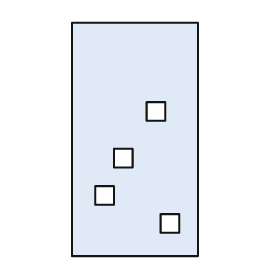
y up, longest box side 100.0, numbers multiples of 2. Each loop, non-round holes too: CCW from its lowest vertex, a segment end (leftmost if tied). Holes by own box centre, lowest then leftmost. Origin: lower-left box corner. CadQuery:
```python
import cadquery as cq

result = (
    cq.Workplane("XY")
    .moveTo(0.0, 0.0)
    .lineTo(54.0, 0.0)
    .lineTo(54.0, 100.0)
    .lineTo(0.0, 100.0)
    .close()
    .moveTo(38.0, 10.0)
    .lineTo(46.0, 10.0)
    .lineTo(46.0, 18.0)
    .lineTo(38.0, 18.0)
    .close()
    .moveTo(10.0, 22.0)
    .lineTo(18.0, 22.0)
    .lineTo(18.0, 30.0)
    .lineTo(10.0, 30.0)
    .close()
    .moveTo(18.0, 38.0)
    .lineTo(26.0, 38.0)
    .lineTo(26.0, 46.0)
    .lineTo(18.0, 46.0)
    .close()
    .moveTo(32.0, 58.0)
    .lineTo(40.0, 58.0)
    .lineTo(40.0, 66.0)
    .lineTo(32.0, 66.0)
    .close()
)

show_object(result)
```